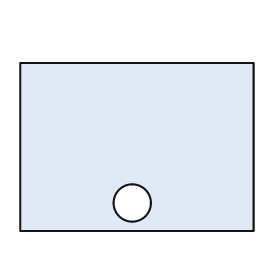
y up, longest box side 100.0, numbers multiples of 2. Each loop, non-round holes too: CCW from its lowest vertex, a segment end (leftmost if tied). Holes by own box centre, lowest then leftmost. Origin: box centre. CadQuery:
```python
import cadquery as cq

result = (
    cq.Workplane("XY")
    .moveTo(-50.0, -36.0)
    .lineTo(50.0, -36.0)
    .lineTo(50.0, 36.0)
    .lineTo(-50.0, 36.0)
    .close()
    .moveTo(-2.0, -24.0)
    .circle(8.0)
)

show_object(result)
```